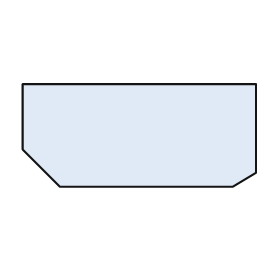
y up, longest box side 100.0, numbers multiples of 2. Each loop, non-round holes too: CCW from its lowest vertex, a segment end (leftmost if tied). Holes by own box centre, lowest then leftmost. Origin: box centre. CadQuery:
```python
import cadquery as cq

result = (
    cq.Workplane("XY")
    .moveTo(-34.0, -22.0)
    .lineTo(40.0, -22.0)
    .lineTo(50.0, -16.0)
    .lineTo(50.0, 22.0)
    .lineTo(-50.0, 22.0)
    .lineTo(-50.0, -6.0)
    .close()
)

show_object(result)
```